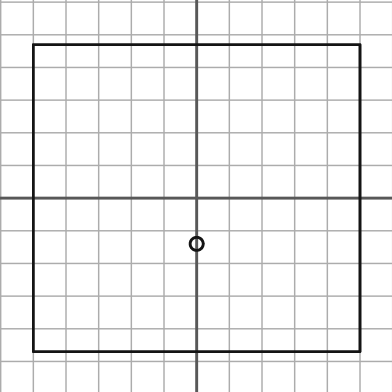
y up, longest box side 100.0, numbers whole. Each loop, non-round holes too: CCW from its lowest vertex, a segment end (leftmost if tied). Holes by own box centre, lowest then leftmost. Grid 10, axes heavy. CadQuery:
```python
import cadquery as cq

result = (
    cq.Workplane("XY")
    .moveTo(-50.0, -47.0)
    .lineTo(50.0, -47.0)
    .lineTo(50.0, 47.0)
    .lineTo(-50.0, 47.0)
    .close()
    .moveTo(0.0, -14.0)
    .circle(2.0)
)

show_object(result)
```